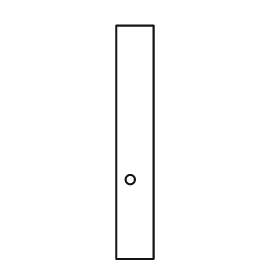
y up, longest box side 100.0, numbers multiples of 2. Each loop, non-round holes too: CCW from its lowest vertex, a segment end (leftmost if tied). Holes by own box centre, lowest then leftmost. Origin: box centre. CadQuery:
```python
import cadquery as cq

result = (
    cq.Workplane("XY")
    .moveTo(-8.0, -50.0)
    .lineTo(8.0, -50.0)
    .lineTo(8.0, 50.0)
    .lineTo(-8.0, 50.0)
    .close()
    .moveTo(-2.0, -16.0)
    .circle(2.0)
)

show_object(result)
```